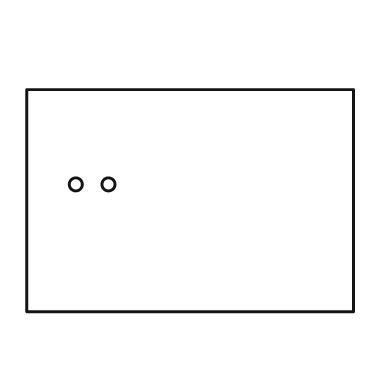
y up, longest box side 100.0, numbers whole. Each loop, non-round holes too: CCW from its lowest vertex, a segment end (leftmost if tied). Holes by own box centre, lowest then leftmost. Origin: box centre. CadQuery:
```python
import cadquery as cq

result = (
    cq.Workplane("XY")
    .moveTo(-50.0, -34.0)
    .lineTo(50.0, -34.0)
    .lineTo(50.0, 34.0)
    .lineTo(-50.0, 34.0)
    .close()
    .moveTo(-35.0, 5.0)
    .circle(2.0)
    .moveTo(-25.0, 5.0)
    .circle(2.0)
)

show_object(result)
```